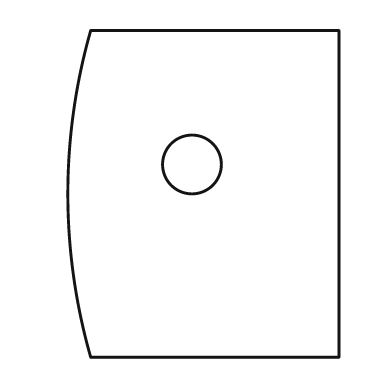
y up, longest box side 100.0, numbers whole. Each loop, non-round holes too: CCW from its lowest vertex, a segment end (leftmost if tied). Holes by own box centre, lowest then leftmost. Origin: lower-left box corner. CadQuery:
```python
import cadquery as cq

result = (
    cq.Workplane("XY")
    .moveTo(7.0, 0.0)
    .lineTo(83.0, 0.0)
    .lineTo(83.0, 100.0)
    .lineTo(7.0, 100.0)
    .threePointArc((0.0, 50.0), (7.0, 0.0))
    .close()
    .moveTo(38.0, 59.0)
    .circle(9.0)
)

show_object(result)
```